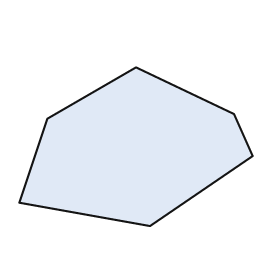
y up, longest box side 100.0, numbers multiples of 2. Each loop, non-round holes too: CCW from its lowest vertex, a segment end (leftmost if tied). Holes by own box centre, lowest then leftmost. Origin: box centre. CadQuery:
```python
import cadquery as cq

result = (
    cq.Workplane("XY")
    .moveTo(6.0, -34.0)
    .lineTo(50.0, -4.0)
    .lineTo(42.0, 14.0)
    .lineTo(0.0, 34.0)
    .lineTo(-38.0, 12.0)
    .lineTo(-50.0, -24.0)
    .close()
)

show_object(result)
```